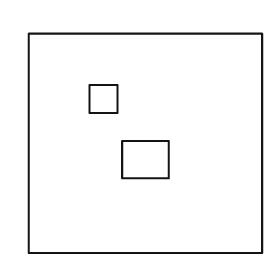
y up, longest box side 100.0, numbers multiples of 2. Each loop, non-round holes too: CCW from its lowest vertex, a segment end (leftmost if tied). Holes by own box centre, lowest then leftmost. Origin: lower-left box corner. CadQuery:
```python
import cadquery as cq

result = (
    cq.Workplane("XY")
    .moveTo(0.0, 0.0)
    .lineTo(100.0, 0.0)
    .lineTo(100.0, 94.0)
    .lineTo(0.0, 94.0)
    .close()
    .moveTo(40.0, 32.0)
    .lineTo(60.0, 32.0)
    .lineTo(60.0, 48.0)
    .lineTo(40.0, 48.0)
    .close()
    .moveTo(26.0, 60.0)
    .lineTo(38.0, 60.0)
    .lineTo(38.0, 72.0)
    .lineTo(26.0, 72.0)
    .close()
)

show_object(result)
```